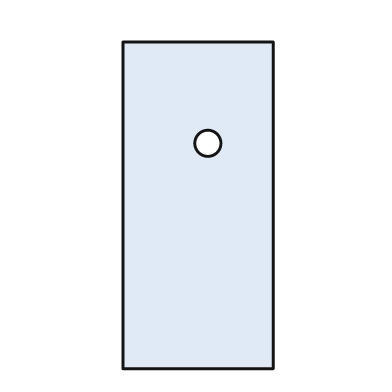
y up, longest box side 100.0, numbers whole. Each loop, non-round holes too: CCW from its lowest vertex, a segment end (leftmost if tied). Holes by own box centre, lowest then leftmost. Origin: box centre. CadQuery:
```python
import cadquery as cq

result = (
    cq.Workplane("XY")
    .moveTo(-23.0, -50.0)
    .lineTo(23.0, -50.0)
    .lineTo(23.0, 50.0)
    .lineTo(-23.0, 50.0)
    .close()
    .moveTo(3.0, 19.0)
    .circle(4.0)
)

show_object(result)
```